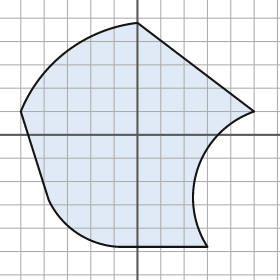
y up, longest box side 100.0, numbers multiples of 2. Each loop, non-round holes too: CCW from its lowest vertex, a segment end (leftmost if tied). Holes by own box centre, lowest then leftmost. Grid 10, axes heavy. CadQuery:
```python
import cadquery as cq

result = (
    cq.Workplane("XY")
    .moveTo(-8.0, -48.0)
    .lineTo(30.0, -48.0)
    .threePointArc((26.0, -14.0), (50.0, 10.0))
    .lineTo(0.0, 48.0)
    .threePointArc((-30.0, 36.0), (-50.0, 10.0))
    .lineTo(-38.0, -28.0)
    .threePointArc((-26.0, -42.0), (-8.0, -48.0))
    .close()
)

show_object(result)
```